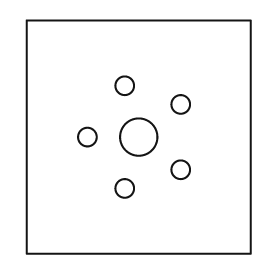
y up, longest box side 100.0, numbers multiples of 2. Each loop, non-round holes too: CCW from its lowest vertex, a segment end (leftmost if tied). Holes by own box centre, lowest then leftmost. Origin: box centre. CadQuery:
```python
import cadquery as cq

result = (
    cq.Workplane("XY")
    .moveTo(-48.0, -50.0)
    .lineTo(48.0, -50.0)
    .lineTo(48.0, 50.0)
    .lineTo(-48.0, 50.0)
    .close()
    .moveTo(-6.0, -22.0)
    .circle(4.0)
    .moveTo(18.0, -14.0)
    .circle(4.0)
    .moveTo(-22.0, 0.0)
    .circle(4.0)
    .moveTo(0.0, 0.0)
    .circle(8.0)
    .moveTo(18.0, 14.0)
    .circle(4.0)
    .moveTo(-6.0, 22.0)
    .circle(4.0)
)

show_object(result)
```